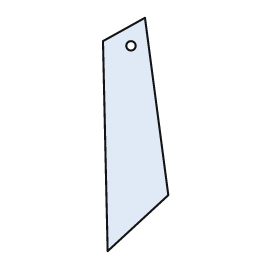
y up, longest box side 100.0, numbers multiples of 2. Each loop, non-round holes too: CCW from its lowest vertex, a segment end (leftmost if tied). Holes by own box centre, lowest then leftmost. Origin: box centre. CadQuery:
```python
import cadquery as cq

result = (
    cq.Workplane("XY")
    .moveTo(-12.0, -50.0)
    .lineTo(14.0, -26.0)
    .lineTo(4.0, 50.0)
    .lineTo(-14.0, 40.0)
    .close()
    .moveTo(-2.0, 38.0)
    .circle(2.0)
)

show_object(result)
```